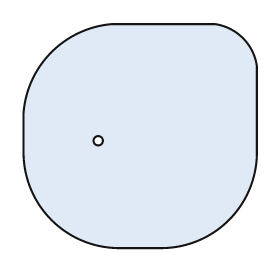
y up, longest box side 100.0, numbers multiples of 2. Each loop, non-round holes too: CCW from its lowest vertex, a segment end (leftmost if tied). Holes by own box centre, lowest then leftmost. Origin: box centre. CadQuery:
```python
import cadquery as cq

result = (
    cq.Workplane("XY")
    .moveTo(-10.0, -48.0)
    .lineTo(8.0, -48.0)
    .threePointArc((38.0, -36.0), (50.0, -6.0))
    .lineTo(50.0, 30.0)
    .threePointArc((44.0, 42.0), (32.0, 48.0))
    .lineTo(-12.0, 48.0)
    .threePointArc((-38.0, 36.0), (-50.0, 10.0))
    .lineTo(-50.0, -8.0)
    .threePointArc((-38.0, -36.0), (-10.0, -48.0))
    .close()
    .moveTo(-18.0, -2.0)
    .circle(2.0)
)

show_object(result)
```